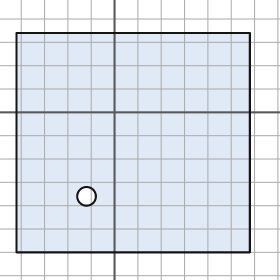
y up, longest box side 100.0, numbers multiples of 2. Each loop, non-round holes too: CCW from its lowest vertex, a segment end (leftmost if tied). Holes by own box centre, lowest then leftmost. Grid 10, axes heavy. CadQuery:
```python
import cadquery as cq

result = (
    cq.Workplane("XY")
    .moveTo(-42.0, -60.0)
    .lineTo(58.0, -60.0)
    .lineTo(58.0, 34.0)
    .lineTo(-42.0, 34.0)
    .close()
    .moveTo(-12.0, -36.0)
    .circle(4.0)
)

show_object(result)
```